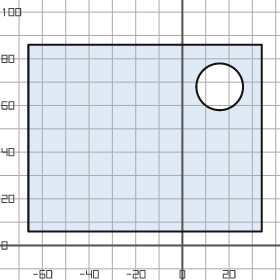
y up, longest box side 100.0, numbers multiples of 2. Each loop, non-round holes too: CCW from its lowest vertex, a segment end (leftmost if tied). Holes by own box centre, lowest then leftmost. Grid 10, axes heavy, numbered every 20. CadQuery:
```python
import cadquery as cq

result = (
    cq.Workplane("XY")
    .moveTo(-66.0, 6.0)
    .lineTo(34.0, 6.0)
    .lineTo(34.0, 86.0)
    .lineTo(-66.0, 86.0)
    .close()
    .moveTo(16.0, 68.0)
    .circle(10.0)
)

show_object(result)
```